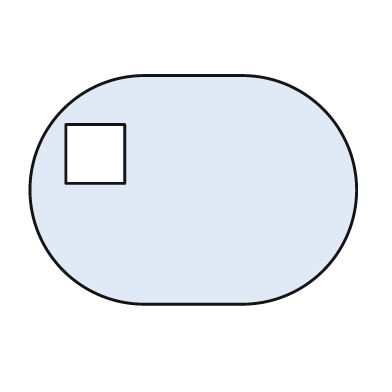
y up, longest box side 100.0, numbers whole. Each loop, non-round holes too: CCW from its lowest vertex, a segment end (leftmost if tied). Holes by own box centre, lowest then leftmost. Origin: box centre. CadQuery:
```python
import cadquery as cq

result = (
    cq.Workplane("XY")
    .moveTo(-15.0, -35.0)
    .lineTo(15.0, -35.0)
    .threePointArc((50.0, 0.0), (15.0, 35.0))
    .lineTo(-15.0, 35.0)
    .threePointArc((-50.0, 0.0), (-15.0, -35.0))
    .close()
    .moveTo(-39.0, 2.0)
    .lineTo(-21.0, 2.0)
    .lineTo(-21.0, 20.0)
    .lineTo(-39.0, 20.0)
    .close()
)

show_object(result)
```